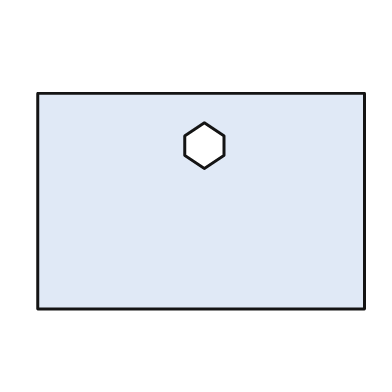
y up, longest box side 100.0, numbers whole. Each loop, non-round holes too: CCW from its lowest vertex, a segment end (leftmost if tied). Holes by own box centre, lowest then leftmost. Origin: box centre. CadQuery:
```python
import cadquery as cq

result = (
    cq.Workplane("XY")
    .moveTo(-50.0, -33.0)
    .lineTo(50.0, -33.0)
    .lineTo(50.0, 33.0)
    .lineTo(-50.0, 33.0)
    .close()
    .moveTo(1.0, 10.0)
    .lineTo(7.0, 14.0)
    .lineTo(7.0, 20.0)
    .lineTo(1.0, 24.0)
    .lineTo(-5.0, 20.0)
    .lineTo(-5.0, 14.0)
    .close()
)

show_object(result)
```